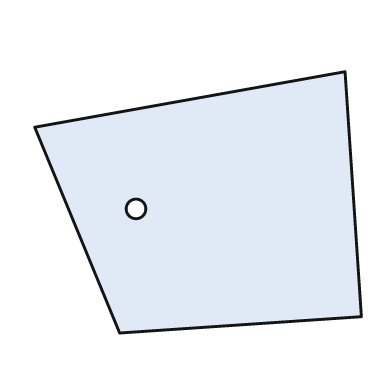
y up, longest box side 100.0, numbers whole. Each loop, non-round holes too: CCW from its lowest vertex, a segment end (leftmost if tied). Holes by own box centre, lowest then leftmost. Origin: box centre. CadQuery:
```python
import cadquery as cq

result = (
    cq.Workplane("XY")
    .moveTo(-24.0, -40.0)
    .lineTo(50.0, -35.0)
    .lineTo(45.0, 40.0)
    .lineTo(-50.0, 23.0)
    .close()
    .moveTo(-19.0, -2.0)
    .circle(3.0)
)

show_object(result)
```